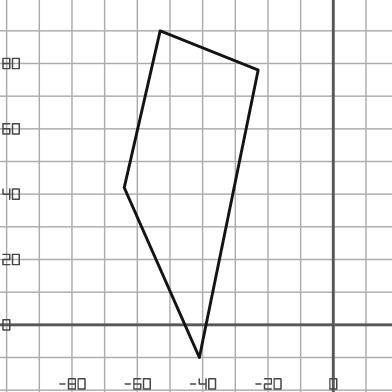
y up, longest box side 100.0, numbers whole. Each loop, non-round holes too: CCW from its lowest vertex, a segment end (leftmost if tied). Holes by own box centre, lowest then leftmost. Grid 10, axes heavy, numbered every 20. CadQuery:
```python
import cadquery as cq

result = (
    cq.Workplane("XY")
    .moveTo(-41.0, -10.0)
    .lineTo(-23.0, 78.0)
    .lineTo(-53.0, 90.0)
    .lineTo(-64.0, 42.0)
    .close()
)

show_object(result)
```